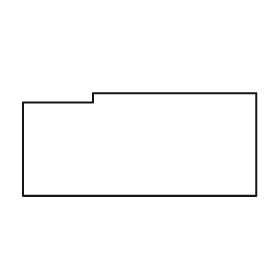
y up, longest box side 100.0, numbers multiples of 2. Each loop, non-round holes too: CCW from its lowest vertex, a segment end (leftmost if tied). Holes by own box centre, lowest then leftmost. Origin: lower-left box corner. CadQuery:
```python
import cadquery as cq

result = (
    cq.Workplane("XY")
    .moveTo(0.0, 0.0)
    .lineTo(100.0, 0.0)
    .lineTo(100.0, 44.0)
    .lineTo(30.0, 44.0)
    .lineTo(30.0, 40.0)
    .lineTo(0.0, 40.0)
    .close()
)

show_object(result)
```